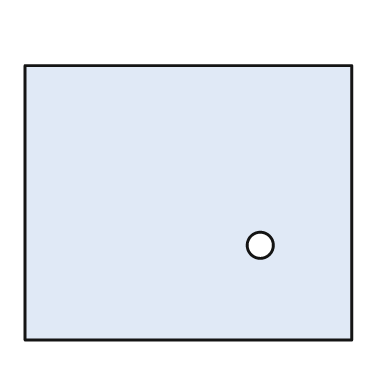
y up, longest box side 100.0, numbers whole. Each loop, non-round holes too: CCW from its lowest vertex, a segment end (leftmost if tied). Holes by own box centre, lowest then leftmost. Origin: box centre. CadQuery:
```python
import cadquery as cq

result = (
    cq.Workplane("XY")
    .moveTo(-50.0, -42.0)
    .lineTo(50.0, -42.0)
    .lineTo(50.0, 42.0)
    .lineTo(-50.0, 42.0)
    .close()
    .moveTo(22.0, -13.0)
    .circle(4.0)
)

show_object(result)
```